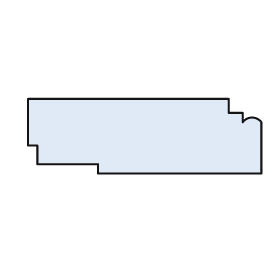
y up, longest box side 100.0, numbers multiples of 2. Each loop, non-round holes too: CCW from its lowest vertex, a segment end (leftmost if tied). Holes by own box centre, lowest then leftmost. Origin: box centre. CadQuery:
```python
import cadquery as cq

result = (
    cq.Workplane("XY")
    .moveTo(-20.0, -16.0)
    .lineTo(50.0, -16.0)
    .lineTo(50.0, 6.0)
    .threePointArc((46.0, 8.0), (42.0, 6.0))
    .lineTo(42.0, 10.0)
    .lineTo(36.0, 10.0)
    .lineTo(36.0, 16.0)
    .lineTo(-50.0, 16.0)
    .lineTo(-50.0, -4.0)
    .lineTo(-46.0, -4.0)
    .lineTo(-46.0, -12.0)
    .lineTo(-20.0, -12.0)
    .close()
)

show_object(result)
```